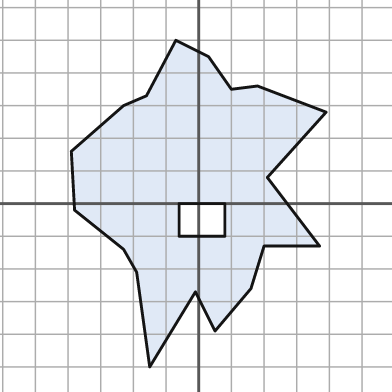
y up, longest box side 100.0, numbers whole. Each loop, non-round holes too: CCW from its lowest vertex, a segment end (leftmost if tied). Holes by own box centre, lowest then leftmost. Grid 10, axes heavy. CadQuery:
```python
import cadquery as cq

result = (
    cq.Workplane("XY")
    .moveTo(-15.0, -50.0)
    .lineTo(-1.0, -27.0)
    .lineTo(5.0, -39.0)
    .lineTo(16.0, -26.0)
    .lineTo(20.0, -13.0)
    .lineTo(37.0, -13.0)
    .lineTo(21.0, 8.0)
    .lineTo(39.0, 28.0)
    .lineTo(18.0, 36.0)
    .lineTo(10.0, 35.0)
    .lineTo(3.0, 45.0)
    .lineTo(-7.0, 50.0)
    .lineTo(-16.0, 33.0)
    .lineTo(-23.0, 30.0)
    .lineTo(-39.0, 16.0)
    .lineTo(-38.0, -2.0)
    .lineTo(-23.0, -14.0)
    .lineTo(-19.0, -21.0)
    .close()
    .moveTo(-6.0, -10.0)
    .lineTo(8.0, -10.0)
    .lineTo(8.0, 0.0)
    .lineTo(-6.0, 0.0)
    .close()
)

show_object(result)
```